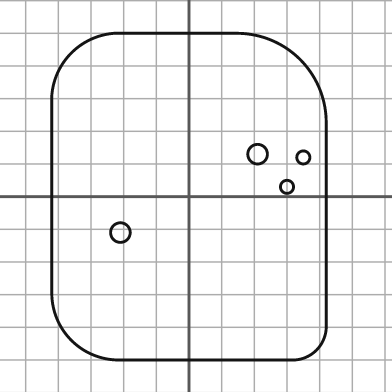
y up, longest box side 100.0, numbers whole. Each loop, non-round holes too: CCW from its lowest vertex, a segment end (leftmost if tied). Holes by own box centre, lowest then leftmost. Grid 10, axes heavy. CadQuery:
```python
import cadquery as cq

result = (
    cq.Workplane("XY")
    .moveTo(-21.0, -50.0)
    .lineTo(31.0, -50.0)
    .threePointArc((39.0, -47.0), (42.0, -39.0))
    .lineTo(42.0, 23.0)
    .threePointArc((34.0, 42.0), (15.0, 50.0))
    .lineTo(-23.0, 50.0)
    .threePointArc((-36.0, 44.0), (-42.0, 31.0))
    .lineTo(-42.0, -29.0)
    .threePointArc((-36.0, -44.0), (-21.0, -50.0))
    .close()
    .moveTo(-21.0, -11.0)
    .circle(3.0)
    .moveTo(30.0, 3.0)
    .circle(2.0)
    .moveTo(35.0, 12.0)
    .circle(2.0)
    .moveTo(21.0, 13.0)
    .circle(3.0)
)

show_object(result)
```